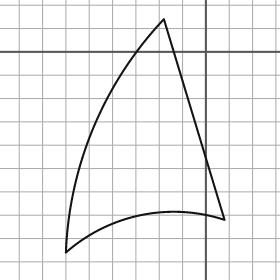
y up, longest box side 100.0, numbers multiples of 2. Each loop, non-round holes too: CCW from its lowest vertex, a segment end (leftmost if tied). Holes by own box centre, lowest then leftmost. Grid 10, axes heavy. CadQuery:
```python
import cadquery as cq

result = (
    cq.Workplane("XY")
    .moveTo(-60.0, -86.0)
    .threePointArc((-28.0, -70.0), (8.0, -72.0))
    .lineTo(-18.0, 14.0)
    .threePointArc((-48.0, -32.0), (-60.0, -86.0))
    .close()
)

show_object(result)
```